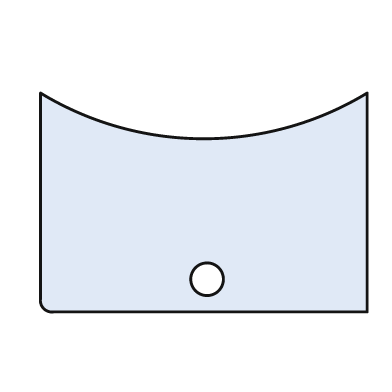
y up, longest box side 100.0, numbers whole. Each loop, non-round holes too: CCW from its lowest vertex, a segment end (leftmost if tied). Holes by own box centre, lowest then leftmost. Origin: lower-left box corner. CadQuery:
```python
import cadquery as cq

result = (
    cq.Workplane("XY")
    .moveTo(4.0, 0.0)
    .lineTo(100.0, 0.0)
    .lineTo(100.0, 67.0)
    .threePointArc((50.0, 53.0), (0.0, 67.0))
    .lineTo(0.0, 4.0)
    .threePointArc((1.0, 1.0), (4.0, 0.0))
    .close()
    .moveTo(51.0, 10.0)
    .circle(5.0)
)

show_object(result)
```